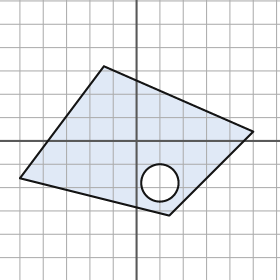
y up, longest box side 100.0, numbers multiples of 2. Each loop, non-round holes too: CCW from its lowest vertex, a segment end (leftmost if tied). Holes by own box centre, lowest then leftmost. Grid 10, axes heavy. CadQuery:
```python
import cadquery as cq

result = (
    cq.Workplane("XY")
    .moveTo(14.0, -32.0)
    .lineTo(50.0, 4.0)
    .lineTo(-14.0, 32.0)
    .lineTo(-50.0, -16.0)
    .close()
    .moveTo(10.0, -18.0)
    .circle(8.0)
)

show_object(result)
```